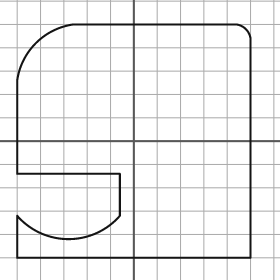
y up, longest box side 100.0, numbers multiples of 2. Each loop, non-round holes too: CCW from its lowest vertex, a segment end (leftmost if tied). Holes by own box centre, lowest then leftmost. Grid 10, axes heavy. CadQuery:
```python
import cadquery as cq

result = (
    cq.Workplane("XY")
    .moveTo(-50.0, -50.0)
    .lineTo(50.0, -50.0)
    .lineTo(50.0, 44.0)
    .threePointArc((48.0, 48.0), (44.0, 50.0))
    .lineTo(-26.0, 50.0)
    .threePointArc((-42.0, 42.0), (-50.0, 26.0))
    .lineTo(-50.0, -14.0)
    .lineTo(-6.0, -14.0)
    .lineTo(-6.0, -32.0)
    .threePointArc((-28.0, -42.0), (-50.0, -32.0))
    .close()
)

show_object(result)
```